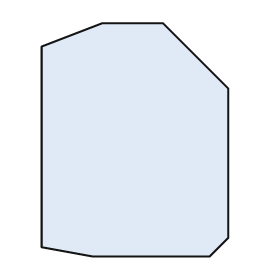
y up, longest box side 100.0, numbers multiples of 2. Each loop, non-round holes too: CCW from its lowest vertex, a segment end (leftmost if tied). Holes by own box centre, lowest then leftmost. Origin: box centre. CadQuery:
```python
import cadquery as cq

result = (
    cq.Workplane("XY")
    .moveTo(-18.0, -50.0)
    .lineTo(32.0, -50.0)
    .lineTo(40.0, -42.0)
    .lineTo(40.0, 22.0)
    .lineTo(12.0, 50.0)
    .lineTo(-14.0, 50.0)
    .lineTo(-40.0, 40.0)
    .lineTo(-40.0, -46.0)
    .close()
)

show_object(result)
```